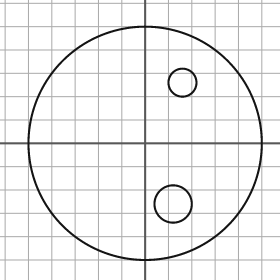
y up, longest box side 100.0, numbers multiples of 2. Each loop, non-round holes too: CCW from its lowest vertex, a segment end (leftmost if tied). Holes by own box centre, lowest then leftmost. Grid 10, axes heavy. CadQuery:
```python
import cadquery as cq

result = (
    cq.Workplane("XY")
    .moveTo(0.0, 0.0)
    .circle(50.0)
    .moveTo(12.0, -26.0)
    .circle(8.0)
    .moveTo(16.0, 26.0)
    .circle(6.0)
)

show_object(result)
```